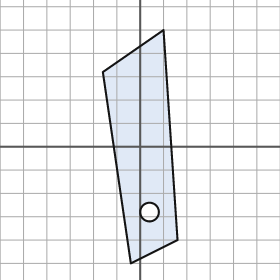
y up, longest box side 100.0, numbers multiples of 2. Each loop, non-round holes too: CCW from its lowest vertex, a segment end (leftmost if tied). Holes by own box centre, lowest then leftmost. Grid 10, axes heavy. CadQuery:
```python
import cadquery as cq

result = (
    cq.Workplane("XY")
    .moveTo(-4.0, -50.0)
    .lineTo(16.0, -40.0)
    .lineTo(10.0, 50.0)
    .lineTo(-16.0, 32.0)
    .close()
    .moveTo(4.0, -28.0)
    .circle(4.0)
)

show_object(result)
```